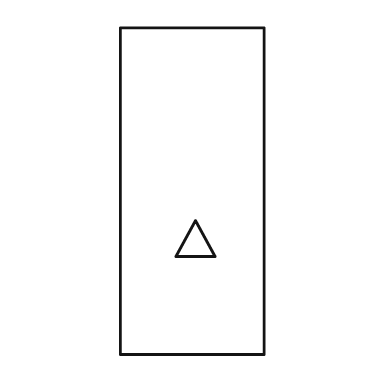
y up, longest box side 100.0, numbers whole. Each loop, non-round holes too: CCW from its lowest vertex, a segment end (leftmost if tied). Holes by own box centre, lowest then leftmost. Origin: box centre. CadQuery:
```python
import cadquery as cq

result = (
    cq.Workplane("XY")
    .moveTo(-22.0, -50.0)
    .lineTo(22.0, -50.0)
    .lineTo(22.0, 50.0)
    .lineTo(-22.0, 50.0)
    .close()
    .moveTo(-5.0, -20.0)
    .lineTo(7.0, -20.0)
    .lineTo(1.0, -9.0)
    .close()
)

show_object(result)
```